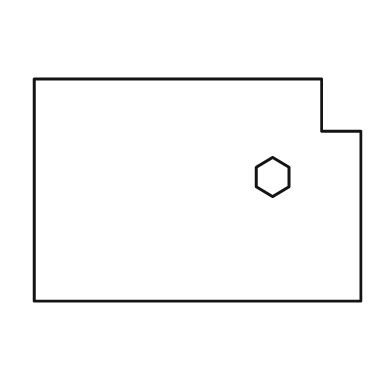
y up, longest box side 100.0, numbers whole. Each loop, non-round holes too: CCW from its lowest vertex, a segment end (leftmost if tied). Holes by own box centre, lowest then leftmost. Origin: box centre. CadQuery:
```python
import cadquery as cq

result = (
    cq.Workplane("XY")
    .moveTo(-50.0, -34.0)
    .lineTo(50.0, -34.0)
    .lineTo(50.0, 18.0)
    .lineTo(38.0, 18.0)
    .lineTo(38.0, 34.0)
    .lineTo(-50.0, 34.0)
    .close()
    .moveTo(23.0, -2.0)
    .lineTo(28.0, 1.0)
    .lineTo(28.0, 7.0)
    .lineTo(23.0, 10.0)
    .lineTo(18.0, 7.0)
    .lineTo(18.0, 1.0)
    .close()
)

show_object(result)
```